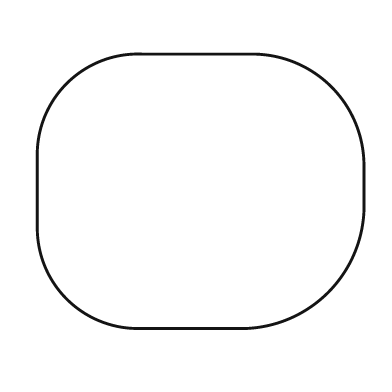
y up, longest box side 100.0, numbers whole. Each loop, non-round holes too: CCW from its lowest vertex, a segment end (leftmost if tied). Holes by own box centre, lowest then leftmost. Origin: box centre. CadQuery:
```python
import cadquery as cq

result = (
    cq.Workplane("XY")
    .moveTo(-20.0, -42.0)
    .lineTo(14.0, -42.0)
    .threePointArc((39.0, -31.0), (50.0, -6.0))
    .lineTo(50.0, 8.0)
    .threePointArc((40.0, 32.0), (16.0, 42.0))
    .lineTo(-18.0, 42.0)
    .threePointArc((-41.0, 33.0), (-50.0, 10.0))
    .lineTo(-50.0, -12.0)
    .threePointArc((-41.0, -33.0), (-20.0, -42.0))
    .close()
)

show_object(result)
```